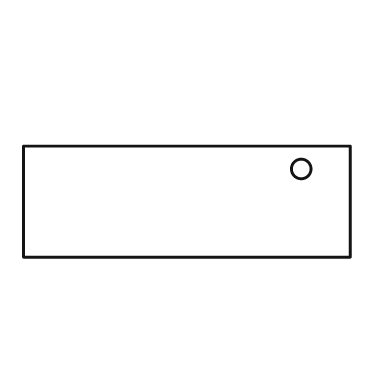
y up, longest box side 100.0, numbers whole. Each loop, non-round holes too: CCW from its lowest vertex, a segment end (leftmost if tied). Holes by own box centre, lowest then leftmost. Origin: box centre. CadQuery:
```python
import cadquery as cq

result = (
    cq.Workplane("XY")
    .moveTo(-50.0, -17.0)
    .lineTo(50.0, -17.0)
    .lineTo(50.0, 17.0)
    .lineTo(-50.0, 17.0)
    .close()
    .moveTo(35.0, 10.0)
    .circle(3.0)
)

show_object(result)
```